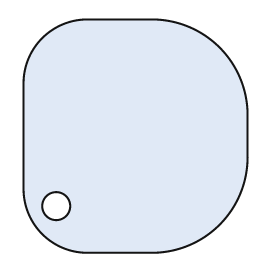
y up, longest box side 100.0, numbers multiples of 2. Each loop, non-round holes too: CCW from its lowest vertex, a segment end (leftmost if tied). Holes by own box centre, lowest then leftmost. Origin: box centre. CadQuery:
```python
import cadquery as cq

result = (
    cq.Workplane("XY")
    .moveTo(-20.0, -50.0)
    .lineTo(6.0, -50.0)
    .threePointArc((36.0, -38.0), (48.0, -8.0))
    .lineTo(48.0, 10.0)
    .threePointArc((36.0, 38.0), (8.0, 50.0))
    .lineTo(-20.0, 50.0)
    .threePointArc((-40.0, 42.0), (-48.0, 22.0))
    .lineTo(-48.0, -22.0)
    .threePointArc((-40.0, -42.0), (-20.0, -50.0))
    .close()
    .moveTo(-34.0, -30.0)
    .circle(6.0)
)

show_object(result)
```